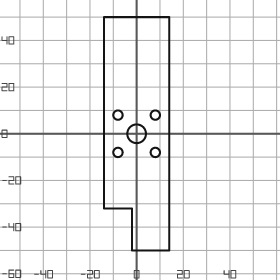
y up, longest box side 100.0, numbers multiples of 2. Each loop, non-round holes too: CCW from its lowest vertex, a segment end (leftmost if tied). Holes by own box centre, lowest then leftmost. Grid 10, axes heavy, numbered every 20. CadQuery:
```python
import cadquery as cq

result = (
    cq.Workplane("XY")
    .moveTo(-2.0, -50.0)
    .lineTo(14.0, -50.0)
    .lineTo(14.0, 50.0)
    .lineTo(-14.0, 50.0)
    .lineTo(-14.0, -32.0)
    .lineTo(-2.0, -32.0)
    .close()
    .moveTo(-8.0, -8.0)
    .circle(2.0)
    .moveTo(8.0, -8.0)
    .circle(2.0)
    .moveTo(0.0, 0.0)
    .circle(4.0)
    .moveTo(-8.0, 8.0)
    .circle(2.0)
    .moveTo(8.0, 8.0)
    .circle(2.0)
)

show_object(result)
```